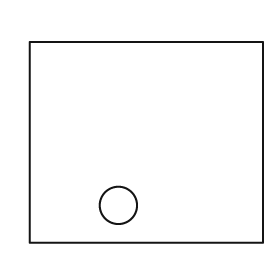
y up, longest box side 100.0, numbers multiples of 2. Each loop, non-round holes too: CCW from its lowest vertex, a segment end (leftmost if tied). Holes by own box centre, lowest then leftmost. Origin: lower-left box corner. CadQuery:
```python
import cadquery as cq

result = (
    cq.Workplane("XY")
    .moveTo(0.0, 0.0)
    .lineTo(100.0, 0.0)
    .lineTo(100.0, 86.0)
    .lineTo(0.0, 86.0)
    .close()
    .moveTo(38.0, 16.0)
    .circle(8.0)
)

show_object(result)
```